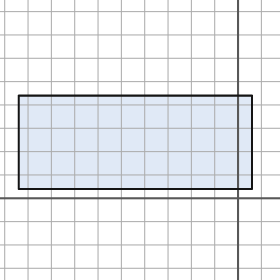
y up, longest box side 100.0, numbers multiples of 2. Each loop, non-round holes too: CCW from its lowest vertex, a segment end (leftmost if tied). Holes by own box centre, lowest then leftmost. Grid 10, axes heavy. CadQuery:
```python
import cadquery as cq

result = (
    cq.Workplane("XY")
    .moveTo(-94.0, 4.0)
    .lineTo(6.0, 4.0)
    .lineTo(6.0, 44.0)
    .lineTo(-94.0, 44.0)
    .close()
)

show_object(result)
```